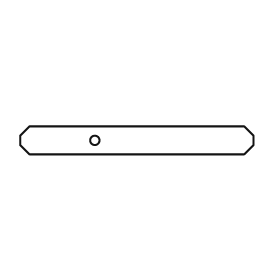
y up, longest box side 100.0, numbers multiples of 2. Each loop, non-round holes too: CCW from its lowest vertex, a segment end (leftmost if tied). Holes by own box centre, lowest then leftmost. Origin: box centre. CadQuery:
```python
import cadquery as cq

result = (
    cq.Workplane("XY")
    .moveTo(-46.0, -6.0)
    .lineTo(46.0, -6.0)
    .lineTo(50.0, -2.0)
    .lineTo(50.0, 2.0)
    .lineTo(46.0, 6.0)
    .lineTo(-46.0, 6.0)
    .lineTo(-50.0, 2.0)
    .lineTo(-50.0, -2.0)
    .close()
    .moveTo(-18.0, 0.0)
    .circle(2.0)
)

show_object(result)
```